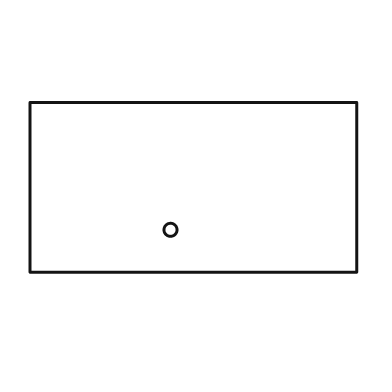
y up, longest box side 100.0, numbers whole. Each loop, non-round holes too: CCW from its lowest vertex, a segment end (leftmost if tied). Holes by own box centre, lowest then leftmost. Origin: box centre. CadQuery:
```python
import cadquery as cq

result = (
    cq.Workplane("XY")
    .moveTo(-50.0, -26.0)
    .lineTo(50.0, -26.0)
    .lineTo(50.0, 26.0)
    .lineTo(-50.0, 26.0)
    .close()
    .moveTo(-7.0, -13.0)
    .circle(2.0)
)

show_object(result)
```